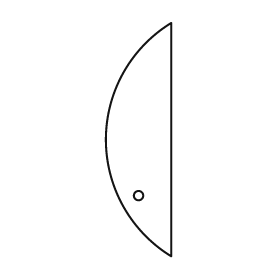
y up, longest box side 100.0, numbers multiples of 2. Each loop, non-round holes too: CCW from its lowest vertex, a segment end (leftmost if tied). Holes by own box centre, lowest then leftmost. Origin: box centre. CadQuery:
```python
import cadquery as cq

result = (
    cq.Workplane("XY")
    .moveTo(14.0, -50.0)
    .lineTo(14.0, 50.0)
    .threePointArc((-14.0, 0.0), (14.0, -50.0))
    .close()
    .moveTo(0.0, -24.0)
    .circle(2.0)
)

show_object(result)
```